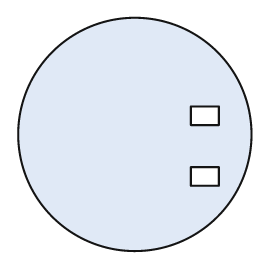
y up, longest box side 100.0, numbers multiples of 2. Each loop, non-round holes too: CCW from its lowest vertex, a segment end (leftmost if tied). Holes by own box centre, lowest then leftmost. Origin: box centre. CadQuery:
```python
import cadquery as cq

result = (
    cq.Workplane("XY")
    .moveTo(0.0, 0.0)
    .circle(50.0)
    .moveTo(24.0, -22.0)
    .lineTo(36.0, -22.0)
    .lineTo(36.0, -14.0)
    .lineTo(24.0, -14.0)
    .close()
    .moveTo(24.0, 4.0)
    .lineTo(36.0, 4.0)
    .lineTo(36.0, 12.0)
    .lineTo(24.0, 12.0)
    .close()
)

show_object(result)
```